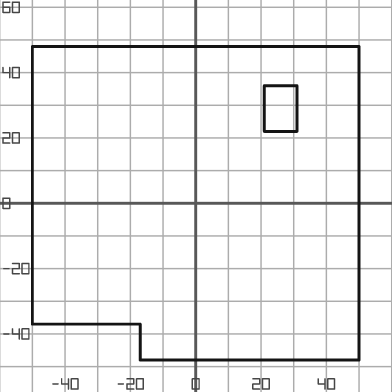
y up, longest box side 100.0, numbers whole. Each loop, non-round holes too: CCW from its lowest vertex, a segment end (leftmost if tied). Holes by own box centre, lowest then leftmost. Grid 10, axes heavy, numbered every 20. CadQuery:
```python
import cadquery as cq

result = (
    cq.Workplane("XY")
    .moveTo(-17.0, -48.0)
    .lineTo(50.0, -48.0)
    .lineTo(50.0, 48.0)
    .lineTo(-50.0, 48.0)
    .lineTo(-50.0, -37.0)
    .lineTo(-17.0, -37.0)
    .close()
    .moveTo(21.0, 22.0)
    .lineTo(31.0, 22.0)
    .lineTo(31.0, 36.0)
    .lineTo(21.0, 36.0)
    .close()
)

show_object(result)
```